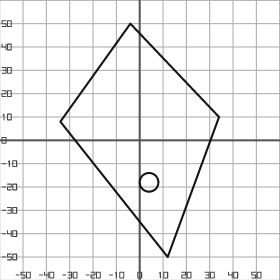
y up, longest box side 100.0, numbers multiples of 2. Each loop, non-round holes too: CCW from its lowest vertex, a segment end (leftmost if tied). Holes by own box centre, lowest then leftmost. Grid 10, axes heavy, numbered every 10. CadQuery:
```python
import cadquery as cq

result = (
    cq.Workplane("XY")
    .moveTo(12.0, -50.0)
    .lineTo(34.0, 10.0)
    .lineTo(-4.0, 50.0)
    .lineTo(-34.0, 8.0)
    .close()
    .moveTo(4.0, -18.0)
    .circle(4.0)
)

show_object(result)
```